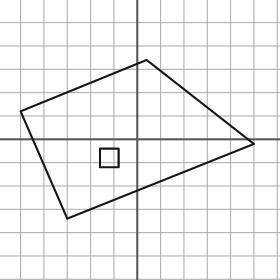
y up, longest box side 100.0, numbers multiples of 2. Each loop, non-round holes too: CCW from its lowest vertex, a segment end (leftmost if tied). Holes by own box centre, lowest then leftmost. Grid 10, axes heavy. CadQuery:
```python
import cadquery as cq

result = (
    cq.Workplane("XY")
    .moveTo(-30.0, -34.0)
    .lineTo(50.0, -2.0)
    .lineTo(4.0, 34.0)
    .lineTo(-50.0, 12.0)
    .close()
    .moveTo(-16.0, -12.0)
    .lineTo(-8.0, -12.0)
    .lineTo(-8.0, -4.0)
    .lineTo(-16.0, -4.0)
    .close()
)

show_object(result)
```